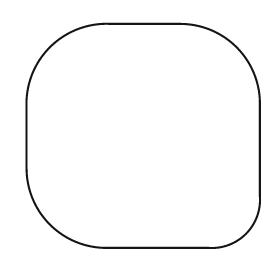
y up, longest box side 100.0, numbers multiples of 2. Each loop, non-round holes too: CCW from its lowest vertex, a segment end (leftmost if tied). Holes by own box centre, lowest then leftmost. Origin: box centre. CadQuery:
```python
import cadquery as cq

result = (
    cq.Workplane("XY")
    .moveTo(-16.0, -48.0)
    .lineTo(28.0, -48.0)
    .threePointArc((44.0, -42.0), (50.0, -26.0))
    .lineTo(50.0, 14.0)
    .threePointArc((40.0, 38.0), (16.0, 48.0))
    .lineTo(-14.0, 48.0)
    .threePointArc((-40.0, 38.0), (-50.0, 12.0))
    .lineTo(-50.0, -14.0)
    .threePointArc((-40.0, -38.0), (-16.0, -48.0))
    .close()
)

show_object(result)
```